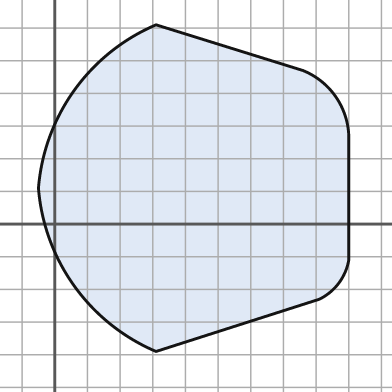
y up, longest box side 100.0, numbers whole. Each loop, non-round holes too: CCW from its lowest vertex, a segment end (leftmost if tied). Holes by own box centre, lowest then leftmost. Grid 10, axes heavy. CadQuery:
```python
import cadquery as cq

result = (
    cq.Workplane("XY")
    .moveTo(31.0, -39.0)
    .lineTo(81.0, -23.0)
    .threePointArc((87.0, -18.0), (90.0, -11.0))
    .lineTo(90.0, 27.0)
    .threePointArc((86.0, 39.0), (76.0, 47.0))
    .lineTo(31.0, 61.0)
    .threePointArc((6.0, 41.0), (-5.0, 11.0))
    .threePointArc((6.0, -19.0), (31.0, -39.0))
    .close()
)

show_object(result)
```